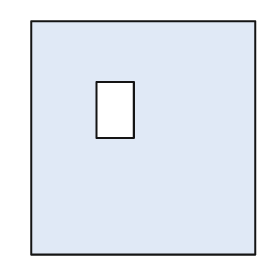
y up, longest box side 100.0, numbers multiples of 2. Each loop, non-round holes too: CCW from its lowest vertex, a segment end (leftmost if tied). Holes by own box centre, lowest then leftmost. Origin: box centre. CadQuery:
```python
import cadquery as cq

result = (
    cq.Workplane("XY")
    .moveTo(-48.0, -50.0)
    .lineTo(48.0, -50.0)
    .lineTo(48.0, 50.0)
    .lineTo(-48.0, 50.0)
    .close()
    .moveTo(-20.0, 0.0)
    .lineTo(-4.0, 0.0)
    .lineTo(-4.0, 24.0)
    .lineTo(-20.0, 24.0)
    .close()
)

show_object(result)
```